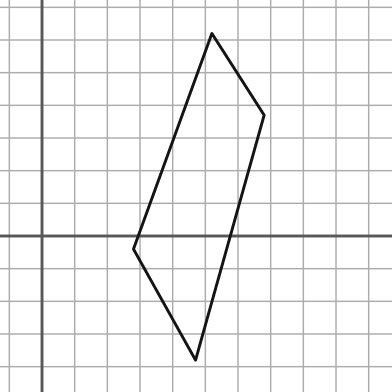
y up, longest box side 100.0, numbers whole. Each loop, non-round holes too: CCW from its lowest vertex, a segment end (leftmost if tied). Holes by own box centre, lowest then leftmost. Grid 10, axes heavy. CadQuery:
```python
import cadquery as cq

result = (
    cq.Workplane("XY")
    .moveTo(47.0, -38.0)
    .lineTo(68.0, 37.0)
    .lineTo(52.0, 62.0)
    .lineTo(28.0, -4.0)
    .close()
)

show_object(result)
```